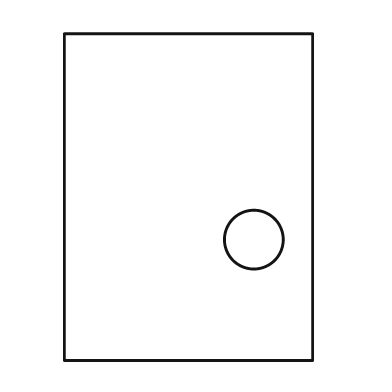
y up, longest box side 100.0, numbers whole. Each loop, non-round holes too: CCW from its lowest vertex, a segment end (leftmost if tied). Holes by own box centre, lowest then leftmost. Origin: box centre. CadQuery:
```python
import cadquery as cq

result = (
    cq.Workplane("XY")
    .moveTo(-38.0, -50.0)
    .lineTo(38.0, -50.0)
    .lineTo(38.0, 50.0)
    .lineTo(-38.0, 50.0)
    .close()
    .moveTo(20.0, -13.0)
    .circle(9.0)
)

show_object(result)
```